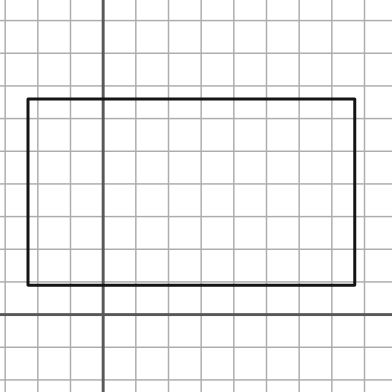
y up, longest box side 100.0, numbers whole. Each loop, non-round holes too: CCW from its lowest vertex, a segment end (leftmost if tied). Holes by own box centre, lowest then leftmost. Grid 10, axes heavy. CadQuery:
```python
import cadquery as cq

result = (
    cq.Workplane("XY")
    .moveTo(-23.0, 9.0)
    .lineTo(77.0, 9.0)
    .lineTo(77.0, 66.0)
    .lineTo(-23.0, 66.0)
    .close()
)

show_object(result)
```